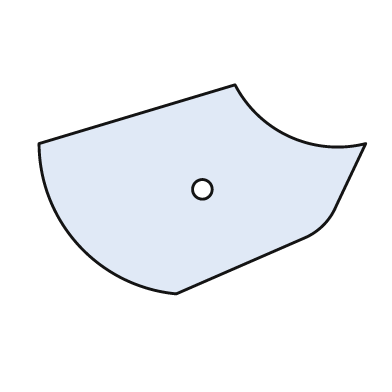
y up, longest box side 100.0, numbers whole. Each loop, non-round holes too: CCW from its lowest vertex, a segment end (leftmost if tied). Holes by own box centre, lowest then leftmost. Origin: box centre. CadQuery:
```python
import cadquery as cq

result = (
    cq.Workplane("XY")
    .moveTo(-8.0, -32.0)
    .lineTo(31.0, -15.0)
    .threePointArc((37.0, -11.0), (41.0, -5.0))
    .lineTo(50.0, 14.0)
    .threePointArc((27.0, 16.0), (10.0, 32.0))
    .lineTo(-50.0, 14.0)
    .threePointArc((-38.0, -17.0), (-8.0, -32.0))
    .close()
    .moveTo(0.0, 0.0)
    .circle(3.0)
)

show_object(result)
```